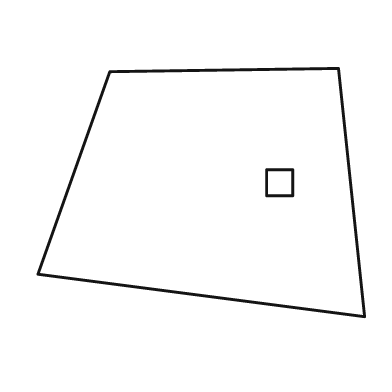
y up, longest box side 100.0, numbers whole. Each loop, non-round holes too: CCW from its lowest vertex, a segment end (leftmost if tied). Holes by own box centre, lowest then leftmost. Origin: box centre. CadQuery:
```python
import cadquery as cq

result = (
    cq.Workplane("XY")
    .moveTo(50.0, -38.0)
    .lineTo(42.0, 38.0)
    .lineTo(-28.0, 37.0)
    .lineTo(-50.0, -25.0)
    .close()
    .moveTo(20.0, -1.0)
    .lineTo(28.0, -1.0)
    .lineTo(28.0, 7.0)
    .lineTo(20.0, 7.0)
    .close()
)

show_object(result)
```